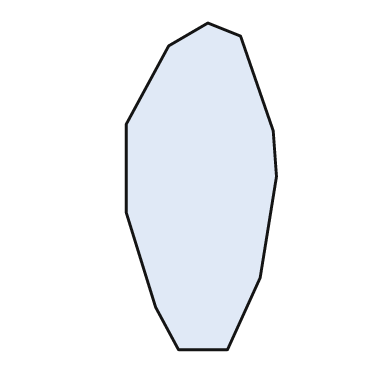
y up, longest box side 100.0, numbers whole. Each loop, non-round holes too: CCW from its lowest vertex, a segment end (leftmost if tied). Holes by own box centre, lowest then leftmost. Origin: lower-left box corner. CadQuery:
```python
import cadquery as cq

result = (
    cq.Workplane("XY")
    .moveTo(16.0, 0.0)
    .lineTo(31.0, 0.0)
    .lineTo(41.0, 22.0)
    .lineTo(46.0, 53.0)
    .lineTo(45.0, 67.0)
    .lineTo(35.0, 96.0)
    .lineTo(25.0, 100.0)
    .lineTo(13.0, 93.0)
    .lineTo(0.0, 69.0)
    .lineTo(0.0, 42.0)
    .lineTo(9.0, 13.0)
    .close()
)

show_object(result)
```